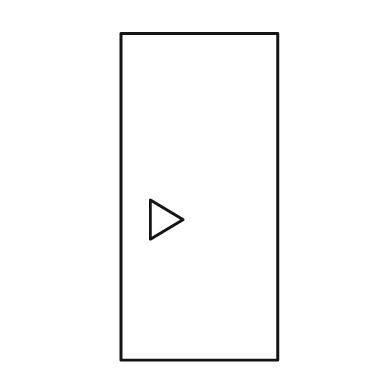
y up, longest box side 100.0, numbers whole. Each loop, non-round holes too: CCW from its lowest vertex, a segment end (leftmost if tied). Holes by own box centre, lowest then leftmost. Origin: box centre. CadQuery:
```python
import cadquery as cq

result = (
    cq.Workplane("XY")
    .moveTo(-24.0, -50.0)
    .lineTo(24.0, -50.0)
    .lineTo(24.0, 50.0)
    .lineTo(-24.0, 50.0)
    .close()
    .moveTo(-15.0, -13.0)
    .lineTo(-5.0, -7.0)
    .lineTo(-15.0, -1.0)
    .close()
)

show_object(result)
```